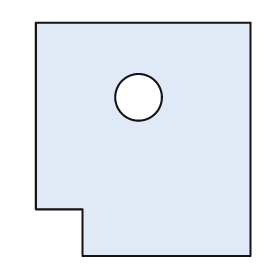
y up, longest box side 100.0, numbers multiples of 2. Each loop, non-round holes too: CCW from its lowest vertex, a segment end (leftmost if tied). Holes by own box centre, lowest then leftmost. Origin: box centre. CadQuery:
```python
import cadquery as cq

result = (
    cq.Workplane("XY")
    .moveTo(-26.0, -50.0)
    .lineTo(46.0, -50.0)
    .lineTo(46.0, 50.0)
    .lineTo(-46.0, 50.0)
    .lineTo(-46.0, -30.0)
    .lineTo(-26.0, -30.0)
    .close()
    .moveTo(-2.0, 18.0)
    .circle(10.0)
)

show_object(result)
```